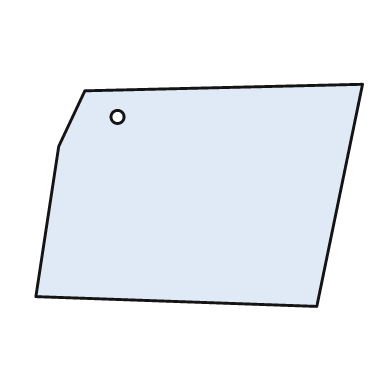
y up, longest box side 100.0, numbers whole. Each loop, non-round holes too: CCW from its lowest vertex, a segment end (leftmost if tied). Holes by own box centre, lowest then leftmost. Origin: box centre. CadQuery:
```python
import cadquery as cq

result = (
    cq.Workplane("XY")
    .moveTo(36.0, -34.0)
    .lineTo(50.0, 34.0)
    .lineTo(-35.0, 32.0)
    .lineTo(-43.0, 15.0)
    .lineTo(-50.0, -31.0)
    .close()
    .moveTo(-25.0, 24.0)
    .circle(2.0)
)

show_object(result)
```